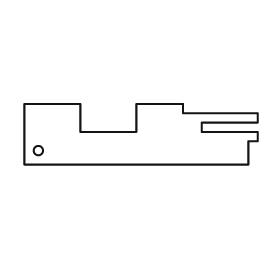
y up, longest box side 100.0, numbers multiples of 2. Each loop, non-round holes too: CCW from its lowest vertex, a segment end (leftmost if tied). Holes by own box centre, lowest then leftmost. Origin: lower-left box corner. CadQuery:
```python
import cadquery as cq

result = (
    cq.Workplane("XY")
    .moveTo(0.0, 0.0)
    .lineTo(96.0, 0.0)
    .lineTo(96.0, 10.0)
    .lineTo(100.0, 10.0)
    .lineTo(100.0, 14.0)
    .lineTo(76.0, 14.0)
    .lineTo(76.0, 18.0)
    .lineTo(100.0, 18.0)
    .lineTo(100.0, 22.0)
    .lineTo(68.0, 22.0)
    .lineTo(68.0, 26.0)
    .lineTo(48.0, 26.0)
    .lineTo(48.0, 14.0)
    .lineTo(24.0, 14.0)
    .lineTo(24.0, 26.0)
    .lineTo(0.0, 26.0)
    .close()
    .moveTo(6.0, 6.0)
    .circle(2.0)
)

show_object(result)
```